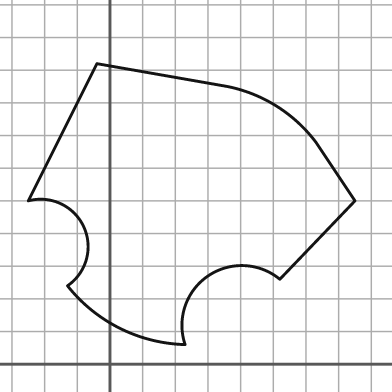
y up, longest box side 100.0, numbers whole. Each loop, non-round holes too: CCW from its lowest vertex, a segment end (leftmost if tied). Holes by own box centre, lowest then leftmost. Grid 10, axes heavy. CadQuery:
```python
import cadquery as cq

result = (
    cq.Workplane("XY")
    .moveTo(23.0, 6.0)
    .threePointArc((30.0, 27.0), (52.0, 26.0))
    .lineTo(75.0, 50.0)
    .lineTo(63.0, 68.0)
    .threePointArc((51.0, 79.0), (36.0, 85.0))
    .lineTo(-4.0, 92.0)
    .lineTo(-25.0, 50.0)
    .threePointArc((-8.0, 42.0), (-13.0, 24.0))
    .threePointArc((3.0, 11.0), (23.0, 6.0))
    .close()
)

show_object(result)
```